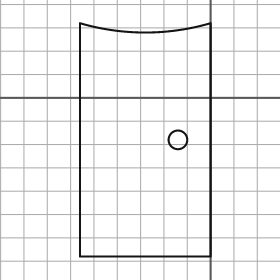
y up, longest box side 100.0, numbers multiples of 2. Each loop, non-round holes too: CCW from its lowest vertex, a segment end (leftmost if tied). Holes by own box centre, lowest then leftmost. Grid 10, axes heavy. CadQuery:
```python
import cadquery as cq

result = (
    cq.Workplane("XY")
    .moveTo(-56.0, -68.0)
    .lineTo(0.0, -68.0)
    .lineTo(0.0, 32.0)
    .threePointArc((-28.0, 28.0), (-56.0, 32.0))
    .close()
    .moveTo(-14.0, -18.0)
    .circle(4.0)
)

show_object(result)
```